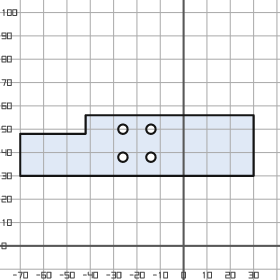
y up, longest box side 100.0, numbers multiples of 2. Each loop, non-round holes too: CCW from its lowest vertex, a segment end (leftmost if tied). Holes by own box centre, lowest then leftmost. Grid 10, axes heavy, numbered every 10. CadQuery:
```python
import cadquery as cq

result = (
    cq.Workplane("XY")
    .moveTo(-70.0, 30.0)
    .lineTo(30.0, 30.0)
    .lineTo(30.0, 56.0)
    .lineTo(-42.0, 56.0)
    .lineTo(-42.0, 48.0)
    .lineTo(-70.0, 48.0)
    .close()
    .moveTo(-26.0, 38.0)
    .circle(2.0)
    .moveTo(-14.0, 38.0)
    .circle(2.0)
    .moveTo(-26.0, 50.0)
    .circle(2.0)
    .moveTo(-14.0, 50.0)
    .circle(2.0)
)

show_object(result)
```